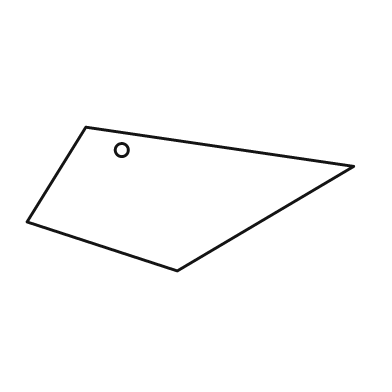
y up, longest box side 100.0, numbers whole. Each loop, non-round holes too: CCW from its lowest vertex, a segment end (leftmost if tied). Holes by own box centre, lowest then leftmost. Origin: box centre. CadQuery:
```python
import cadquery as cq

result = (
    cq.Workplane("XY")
    .moveTo(-4.0, -22.0)
    .lineTo(50.0, 10.0)
    .lineTo(-32.0, 22.0)
    .lineTo(-50.0, -7.0)
    .close()
    .moveTo(-21.0, 15.0)
    .circle(2.0)
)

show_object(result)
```